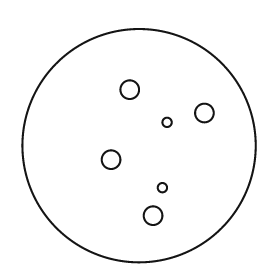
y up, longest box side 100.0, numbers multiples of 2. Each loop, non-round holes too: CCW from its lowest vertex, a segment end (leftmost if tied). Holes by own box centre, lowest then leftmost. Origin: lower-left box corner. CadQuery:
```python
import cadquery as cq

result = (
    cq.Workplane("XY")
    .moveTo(50.0, 50.0)
    .circle(50.0)
    .moveTo(56.0, 20.0)
    .circle(4.0)
    .moveTo(60.0, 32.0)
    .circle(2.0)
    .moveTo(38.0, 44.0)
    .circle(4.0)
    .moveTo(62.0, 60.0)
    .circle(2.0)
    .moveTo(78.0, 64.0)
    .circle(4.0)
    .moveTo(46.0, 74.0)
    .circle(4.0)
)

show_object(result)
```